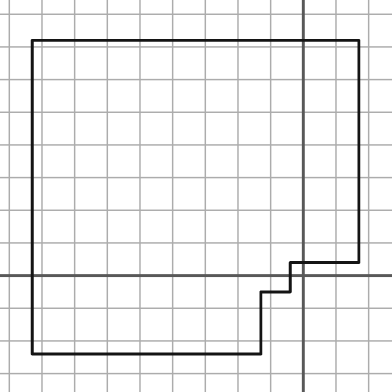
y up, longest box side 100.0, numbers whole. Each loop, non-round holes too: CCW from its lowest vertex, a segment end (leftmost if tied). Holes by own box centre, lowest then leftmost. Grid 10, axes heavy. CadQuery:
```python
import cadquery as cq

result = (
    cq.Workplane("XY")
    .moveTo(-83.0, -24.0)
    .lineTo(-13.0, -24.0)
    .lineTo(-13.0, -5.0)
    .lineTo(-4.0, -5.0)
    .lineTo(-4.0, 4.0)
    .lineTo(17.0, 4.0)
    .lineTo(17.0, 72.0)
    .lineTo(-83.0, 72.0)
    .close()
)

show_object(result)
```